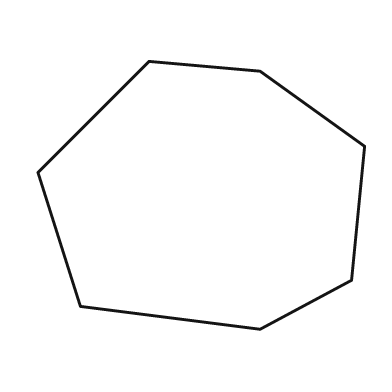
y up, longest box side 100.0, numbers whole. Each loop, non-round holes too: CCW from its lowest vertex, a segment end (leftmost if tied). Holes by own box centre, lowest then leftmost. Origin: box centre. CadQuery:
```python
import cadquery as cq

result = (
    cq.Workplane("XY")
    .moveTo(18.0, -41.0)
    .lineTo(46.0, -26.0)
    .lineTo(50.0, 15.0)
    .lineTo(18.0, 38.0)
    .lineTo(-16.0, 41.0)
    .lineTo(-50.0, 7.0)
    .lineTo(-37.0, -34.0)
    .close()
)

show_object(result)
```